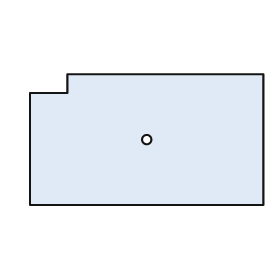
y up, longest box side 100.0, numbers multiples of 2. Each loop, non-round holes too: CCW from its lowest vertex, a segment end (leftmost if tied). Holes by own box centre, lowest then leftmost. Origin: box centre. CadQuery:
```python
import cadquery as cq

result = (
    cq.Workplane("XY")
    .moveTo(-50.0, -28.0)
    .lineTo(50.0, -28.0)
    .lineTo(50.0, 28.0)
    .lineTo(-34.0, 28.0)
    .lineTo(-34.0, 20.0)
    .lineTo(-50.0, 20.0)
    .close()
    .moveTo(0.0, 0.0)
    .circle(2.0)
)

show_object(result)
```